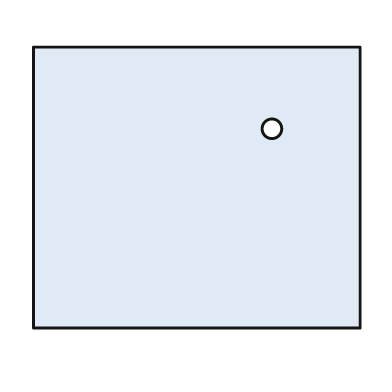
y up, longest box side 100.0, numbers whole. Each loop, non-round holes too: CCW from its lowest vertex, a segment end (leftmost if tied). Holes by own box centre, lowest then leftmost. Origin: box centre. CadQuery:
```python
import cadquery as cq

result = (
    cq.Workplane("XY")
    .moveTo(-50.0, -43.0)
    .lineTo(50.0, -43.0)
    .lineTo(50.0, 43.0)
    .lineTo(-50.0, 43.0)
    .close()
    .moveTo(23.0, 18.0)
    .circle(3.0)
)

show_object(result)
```